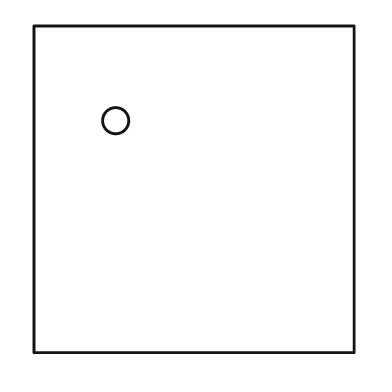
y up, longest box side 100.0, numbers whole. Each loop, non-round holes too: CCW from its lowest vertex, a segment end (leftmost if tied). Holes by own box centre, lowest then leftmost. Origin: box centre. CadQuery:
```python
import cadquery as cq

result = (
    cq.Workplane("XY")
    .moveTo(-49.0, -50.0)
    .lineTo(49.0, -50.0)
    .lineTo(49.0, 50.0)
    .lineTo(-49.0, 50.0)
    .close()
    .moveTo(-24.0, 21.0)
    .circle(4.0)
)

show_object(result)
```